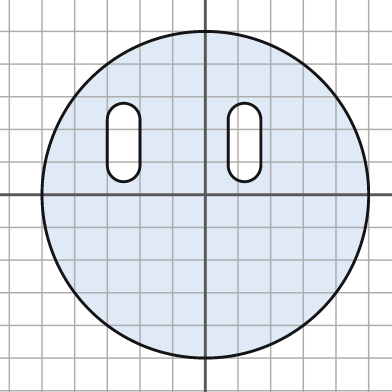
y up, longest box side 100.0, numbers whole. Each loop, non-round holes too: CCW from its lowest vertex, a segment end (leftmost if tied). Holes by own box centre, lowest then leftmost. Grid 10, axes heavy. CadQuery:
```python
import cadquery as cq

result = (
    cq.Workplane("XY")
    .moveTo(0.0, 0.0)
    .circle(50.0)
    .moveTo(-30.0, 9.0)
    .threePointArc((-25.0, 4.0), (-20.0, 9.0))
    .lineTo(-20.0, 23.0)
    .threePointArc((-25.0, 28.0), (-30.0, 23.0))
    .close()
    .moveTo(7.0, 9.0)
    .threePointArc((12.0, 4.0), (17.0, 9.0))
    .lineTo(17.0, 23.0)
    .threePointArc((12.0, 28.0), (7.0, 23.0))
    .close()
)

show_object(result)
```